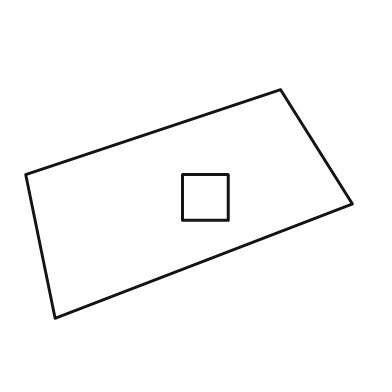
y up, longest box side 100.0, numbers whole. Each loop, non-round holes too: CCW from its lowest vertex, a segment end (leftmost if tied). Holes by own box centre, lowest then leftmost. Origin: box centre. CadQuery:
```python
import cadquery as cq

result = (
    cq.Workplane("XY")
    .moveTo(-41.0, -35.0)
    .lineTo(50.0, 0.0)
    .lineTo(28.0, 35.0)
    .lineTo(-50.0, 9.0)
    .close()
    .moveTo(-2.0, -5.0)
    .lineTo(12.0, -5.0)
    .lineTo(12.0, 9.0)
    .lineTo(-2.0, 9.0)
    .close()
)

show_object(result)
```